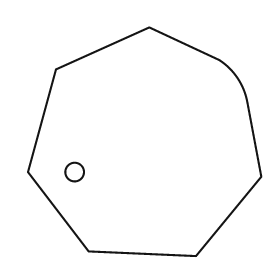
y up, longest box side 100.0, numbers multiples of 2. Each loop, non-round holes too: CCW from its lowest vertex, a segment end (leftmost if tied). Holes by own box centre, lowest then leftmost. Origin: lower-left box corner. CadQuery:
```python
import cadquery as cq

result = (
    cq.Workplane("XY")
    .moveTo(72.0, 0.0)
    .lineTo(100.0, 34.0)
    .lineTo(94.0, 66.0)
    .threePointArc((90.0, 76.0), (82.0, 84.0))
    .lineTo(52.0, 98.0)
    .lineTo(12.0, 80.0)
    .lineTo(0.0, 36.0)
    .lineTo(26.0, 2.0)
    .close()
    .moveTo(20.0, 36.0)
    .circle(4.0)
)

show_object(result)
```